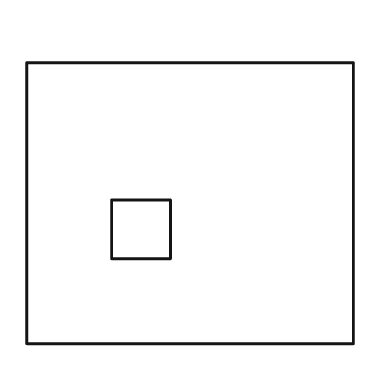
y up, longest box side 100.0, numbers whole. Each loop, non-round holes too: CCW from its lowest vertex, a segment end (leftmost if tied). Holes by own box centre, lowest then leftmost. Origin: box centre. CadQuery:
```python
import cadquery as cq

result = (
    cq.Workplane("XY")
    .moveTo(-50.0, -43.0)
    .lineTo(50.0, -43.0)
    .lineTo(50.0, 43.0)
    .lineTo(-50.0, 43.0)
    .close()
    .moveTo(-24.0, -17.0)
    .lineTo(-6.0, -17.0)
    .lineTo(-6.0, 1.0)
    .lineTo(-24.0, 1.0)
    .close()
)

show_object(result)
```